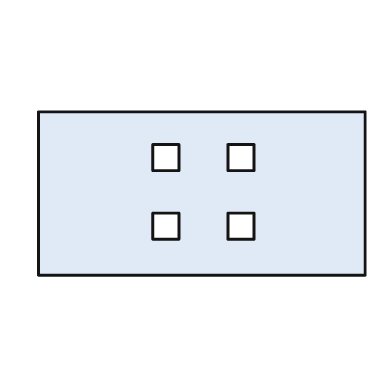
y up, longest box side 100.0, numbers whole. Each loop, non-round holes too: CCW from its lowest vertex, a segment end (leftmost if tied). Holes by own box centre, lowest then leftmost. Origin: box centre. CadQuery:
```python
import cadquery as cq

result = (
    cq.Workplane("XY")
    .moveTo(-50.0, -25.0)
    .lineTo(50.0, -25.0)
    .lineTo(50.0, 25.0)
    .lineTo(-50.0, 25.0)
    .close()
    .moveTo(-15.0, -14.0)
    .lineTo(-7.0, -14.0)
    .lineTo(-7.0, -6.0)
    .lineTo(-15.0, -6.0)
    .close()
    .moveTo(8.0, -14.0)
    .lineTo(16.0, -14.0)
    .lineTo(16.0, -6.0)
    .lineTo(8.0, -6.0)
    .close()
    .moveTo(-15.0, 7.0)
    .lineTo(-7.0, 7.0)
    .lineTo(-7.0, 15.0)
    .lineTo(-15.0, 15.0)
    .close()
    .moveTo(8.0, 7.0)
    .lineTo(16.0, 7.0)
    .lineTo(16.0, 15.0)
    .lineTo(8.0, 15.0)
    .close()
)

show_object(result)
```